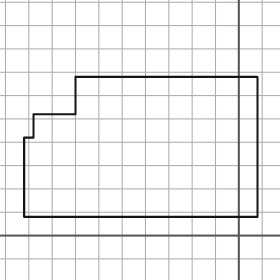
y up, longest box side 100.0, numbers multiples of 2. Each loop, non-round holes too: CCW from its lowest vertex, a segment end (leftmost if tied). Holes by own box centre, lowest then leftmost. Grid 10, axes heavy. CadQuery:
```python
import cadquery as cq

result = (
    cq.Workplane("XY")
    .moveTo(-92.0, 8.0)
    .lineTo(8.0, 8.0)
    .lineTo(8.0, 68.0)
    .lineTo(-70.0, 68.0)
    .lineTo(-70.0, 52.0)
    .lineTo(-88.0, 52.0)
    .lineTo(-88.0, 42.0)
    .lineTo(-92.0, 42.0)
    .close()
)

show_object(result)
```